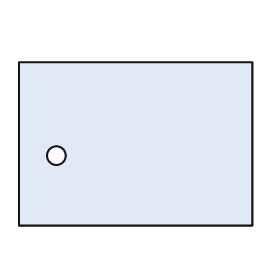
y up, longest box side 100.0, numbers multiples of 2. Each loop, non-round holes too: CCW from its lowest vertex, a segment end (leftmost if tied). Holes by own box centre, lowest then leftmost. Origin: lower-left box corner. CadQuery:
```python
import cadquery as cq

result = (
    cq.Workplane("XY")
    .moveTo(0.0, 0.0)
    .lineTo(100.0, 0.0)
    .lineTo(100.0, 70.0)
    .lineTo(0.0, 70.0)
    .close()
    .moveTo(16.0, 30.0)
    .circle(4.0)
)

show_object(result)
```